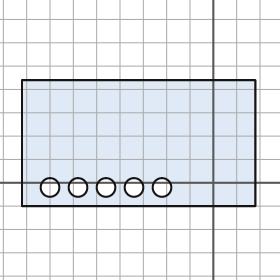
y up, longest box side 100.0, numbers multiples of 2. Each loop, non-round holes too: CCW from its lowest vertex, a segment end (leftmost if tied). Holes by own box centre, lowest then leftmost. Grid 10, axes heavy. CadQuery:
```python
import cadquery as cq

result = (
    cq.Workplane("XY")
    .moveTo(-82.0, -10.0)
    .lineTo(18.0, -10.0)
    .lineTo(18.0, 44.0)
    .lineTo(-82.0, 44.0)
    .close()
    .moveTo(-70.0, -2.0)
    .circle(4.0)
    .moveTo(-58.0, -2.0)
    .circle(4.0)
    .moveTo(-46.0, -2.0)
    .circle(4.0)
    .moveTo(-34.0, -2.0)
    .circle(4.0)
    .moveTo(-22.0, -2.0)
    .circle(4.0)
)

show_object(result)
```